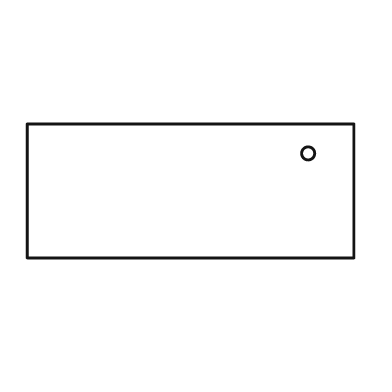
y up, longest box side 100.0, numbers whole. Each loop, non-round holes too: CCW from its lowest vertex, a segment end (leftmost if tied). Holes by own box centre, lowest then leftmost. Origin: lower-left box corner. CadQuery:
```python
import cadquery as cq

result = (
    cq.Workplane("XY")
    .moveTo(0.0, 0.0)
    .lineTo(100.0, 0.0)
    .lineTo(100.0, 41.0)
    .lineTo(0.0, 41.0)
    .close()
    .moveTo(86.0, 32.0)
    .circle(2.0)
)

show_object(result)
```